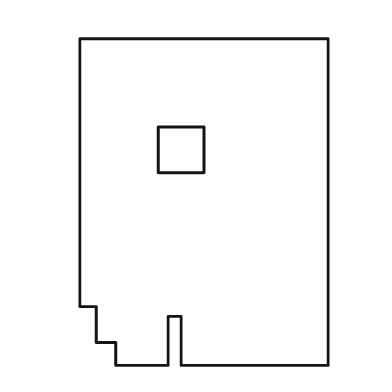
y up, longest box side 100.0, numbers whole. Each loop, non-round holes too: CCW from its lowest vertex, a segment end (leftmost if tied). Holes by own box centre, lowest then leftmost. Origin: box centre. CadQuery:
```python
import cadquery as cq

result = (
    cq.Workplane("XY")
    .moveTo(-27.0, -50.0)
    .lineTo(-11.0, -50.0)
    .lineTo(-11.0, -35.0)
    .lineTo(-7.0, -35.0)
    .lineTo(-7.0, -50.0)
    .lineTo(38.0, -50.0)
    .lineTo(38.0, 50.0)
    .lineTo(-38.0, 50.0)
    .lineTo(-38.0, -32.0)
    .lineTo(-33.0, -32.0)
    .lineTo(-33.0, -43.0)
    .lineTo(-27.0, -43.0)
    .close()
    .moveTo(-14.0, 9.0)
    .lineTo(0.0, 9.0)
    .lineTo(0.0, 23.0)
    .lineTo(-14.0, 23.0)
    .close()
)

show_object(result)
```